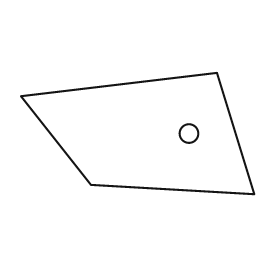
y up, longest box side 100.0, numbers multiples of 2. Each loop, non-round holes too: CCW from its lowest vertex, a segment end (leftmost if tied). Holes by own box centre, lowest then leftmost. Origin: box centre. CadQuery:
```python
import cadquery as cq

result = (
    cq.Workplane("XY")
    .moveTo(50.0, -26.0)
    .lineTo(34.0, 26.0)
    .lineTo(-50.0, 16.0)
    .lineTo(-20.0, -22.0)
    .close()
    .moveTo(22.0, 0.0)
    .circle(4.0)
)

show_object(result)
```